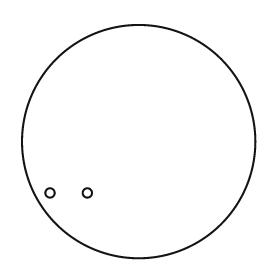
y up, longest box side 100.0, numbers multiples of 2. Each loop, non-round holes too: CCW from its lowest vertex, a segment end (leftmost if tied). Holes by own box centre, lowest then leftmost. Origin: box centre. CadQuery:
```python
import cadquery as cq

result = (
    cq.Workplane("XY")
    .moveTo(0.0, 0.0)
    .circle(50.0)
    .moveTo(-38.0, -22.0)
    .circle(2.0)
    .moveTo(-22.0, -22.0)
    .circle(2.0)
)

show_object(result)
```